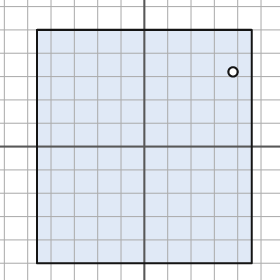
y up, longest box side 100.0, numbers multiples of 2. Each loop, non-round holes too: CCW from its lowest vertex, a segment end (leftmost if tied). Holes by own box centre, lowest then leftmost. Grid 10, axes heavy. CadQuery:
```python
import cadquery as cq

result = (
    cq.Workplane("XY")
    .moveTo(-46.0, -50.0)
    .lineTo(46.0, -50.0)
    .lineTo(46.0, 50.0)
    .lineTo(-46.0, 50.0)
    .close()
    .moveTo(38.0, 32.0)
    .circle(2.0)
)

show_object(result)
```